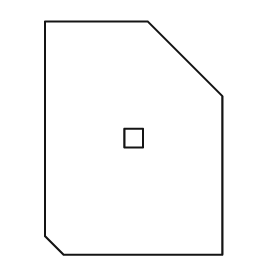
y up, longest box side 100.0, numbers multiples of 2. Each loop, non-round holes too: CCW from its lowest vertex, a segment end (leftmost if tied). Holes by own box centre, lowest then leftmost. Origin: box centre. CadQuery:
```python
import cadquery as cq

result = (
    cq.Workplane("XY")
    .moveTo(-30.0, -50.0)
    .lineTo(38.0, -50.0)
    .lineTo(38.0, 18.0)
    .lineTo(6.0, 50.0)
    .lineTo(-38.0, 50.0)
    .lineTo(-38.0, -42.0)
    .close()
    .moveTo(-4.0, -4.0)
    .lineTo(4.0, -4.0)
    .lineTo(4.0, 4.0)
    .lineTo(-4.0, 4.0)
    .close()
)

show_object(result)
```